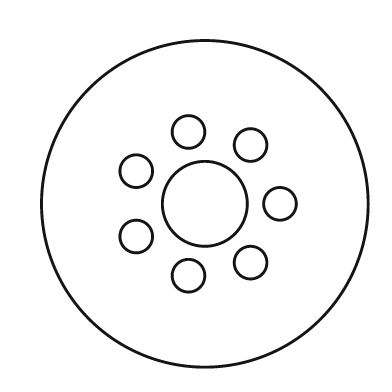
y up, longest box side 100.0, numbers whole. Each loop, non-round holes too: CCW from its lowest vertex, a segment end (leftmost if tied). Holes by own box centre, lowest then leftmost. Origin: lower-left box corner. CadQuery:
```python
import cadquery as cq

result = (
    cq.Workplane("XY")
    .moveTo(50.0, 50.0)
    .circle(50.0)
    .moveTo(45.0, 28.0)
    .circle(5.0)
    .moveTo(64.0, 32.0)
    .circle(5.0)
    .moveTo(29.0, 40.0)
    .circle(5.0)
    .moveTo(50.0, 50.0)
    .circle(13.0)
    .moveTo(73.0, 50.0)
    .circle(5.0)
    .moveTo(29.0, 60.0)
    .circle(5.0)
    .moveTo(64.0, 68.0)
    .circle(5.0)
    .moveTo(45.0, 72.0)
    .circle(5.0)
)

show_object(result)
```